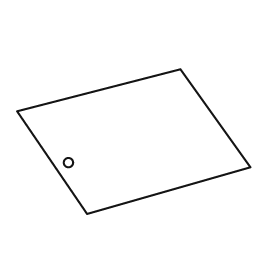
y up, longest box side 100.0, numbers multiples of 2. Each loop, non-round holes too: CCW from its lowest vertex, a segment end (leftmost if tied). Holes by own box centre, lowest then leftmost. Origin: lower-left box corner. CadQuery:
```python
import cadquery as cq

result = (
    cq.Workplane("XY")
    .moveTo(30.0, 0.0)
    .lineTo(100.0, 20.0)
    .lineTo(70.0, 62.0)
    .lineTo(0.0, 44.0)
    .close()
    .moveTo(22.0, 22.0)
    .circle(2.0)
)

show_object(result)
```